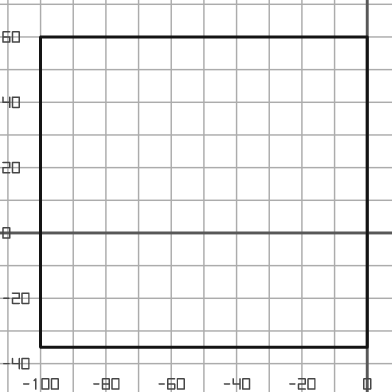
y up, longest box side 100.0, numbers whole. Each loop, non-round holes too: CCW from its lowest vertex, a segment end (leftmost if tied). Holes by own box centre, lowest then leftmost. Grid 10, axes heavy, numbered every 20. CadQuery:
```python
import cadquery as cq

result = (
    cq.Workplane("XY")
    .moveTo(-100.0, -35.0)
    .lineTo(0.0, -35.0)
    .lineTo(0.0, 60.0)
    .lineTo(-100.0, 60.0)
    .close()
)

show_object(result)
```